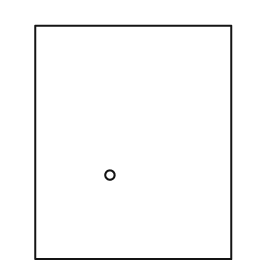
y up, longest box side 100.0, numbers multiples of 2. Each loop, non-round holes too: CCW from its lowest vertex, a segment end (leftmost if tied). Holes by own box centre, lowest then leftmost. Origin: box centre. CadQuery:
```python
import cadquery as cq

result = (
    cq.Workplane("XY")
    .moveTo(-42.0, -50.0)
    .lineTo(42.0, -50.0)
    .lineTo(42.0, 50.0)
    .lineTo(-42.0, 50.0)
    .close()
    .moveTo(-10.0, -14.0)
    .circle(2.0)
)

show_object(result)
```